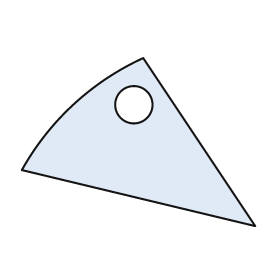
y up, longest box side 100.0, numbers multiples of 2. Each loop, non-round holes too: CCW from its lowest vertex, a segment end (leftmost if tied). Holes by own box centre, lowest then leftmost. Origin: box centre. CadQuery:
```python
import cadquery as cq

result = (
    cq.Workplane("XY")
    .moveTo(50.0, -36.0)
    .lineTo(2.0, 36.0)
    .threePointArc((-28.0, 16.0), (-50.0, -12.0))
    .close()
    .moveTo(-2.0, 16.0)
    .circle(8.0)
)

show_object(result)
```